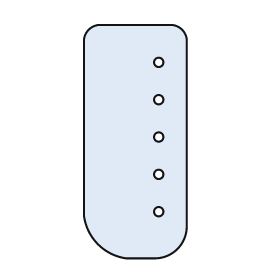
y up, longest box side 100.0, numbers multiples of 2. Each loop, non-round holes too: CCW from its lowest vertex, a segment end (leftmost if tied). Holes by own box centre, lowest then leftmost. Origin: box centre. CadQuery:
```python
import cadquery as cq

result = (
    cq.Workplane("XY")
    .moveTo(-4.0, -50.0)
    .lineTo(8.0, -50.0)
    .threePointArc((18.0, -46.0), (22.0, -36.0))
    .lineTo(22.0, 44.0)
    .threePointArc((20.0, 48.0), (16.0, 50.0))
    .lineTo(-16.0, 50.0)
    .threePointArc((-20.0, 48.0), (-22.0, 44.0))
    .lineTo(-22.0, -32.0)
    .threePointArc((-16.0, -44.0), (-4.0, -50.0))
    .close()
    .moveTo(10.0, -30.0)
    .circle(2.0)
    .moveTo(10.0, -14.0)
    .circle(2.0)
    .moveTo(10.0, 2.0)
    .circle(2.0)
    .moveTo(10.0, 18.0)
    .circle(2.0)
    .moveTo(10.0, 34.0)
    .circle(2.0)
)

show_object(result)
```